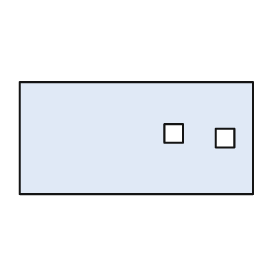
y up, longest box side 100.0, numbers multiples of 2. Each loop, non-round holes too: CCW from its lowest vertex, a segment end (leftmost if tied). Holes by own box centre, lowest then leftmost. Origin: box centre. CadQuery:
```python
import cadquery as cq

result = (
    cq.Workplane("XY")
    .moveTo(-50.0, -24.0)
    .lineTo(50.0, -24.0)
    .lineTo(50.0, 24.0)
    .lineTo(-50.0, 24.0)
    .close()
    .moveTo(34.0, -4.0)
    .lineTo(42.0, -4.0)
    .lineTo(42.0, 4.0)
    .lineTo(34.0, 4.0)
    .close()
    .moveTo(12.0, -2.0)
    .lineTo(20.0, -2.0)
    .lineTo(20.0, 6.0)
    .lineTo(12.0, 6.0)
    .close()
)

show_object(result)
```